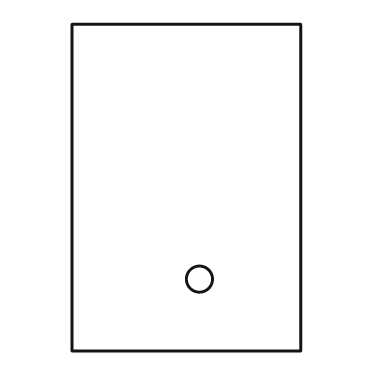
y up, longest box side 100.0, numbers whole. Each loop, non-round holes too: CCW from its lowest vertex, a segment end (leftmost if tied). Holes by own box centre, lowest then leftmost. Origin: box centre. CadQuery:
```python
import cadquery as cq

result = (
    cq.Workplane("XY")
    .moveTo(-35.0, -50.0)
    .lineTo(35.0, -50.0)
    .lineTo(35.0, 50.0)
    .lineTo(-35.0, 50.0)
    .close()
    .moveTo(4.0, -28.0)
    .circle(4.0)
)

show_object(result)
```